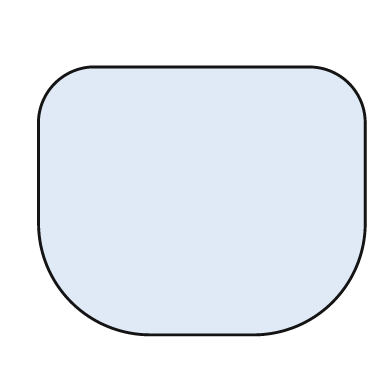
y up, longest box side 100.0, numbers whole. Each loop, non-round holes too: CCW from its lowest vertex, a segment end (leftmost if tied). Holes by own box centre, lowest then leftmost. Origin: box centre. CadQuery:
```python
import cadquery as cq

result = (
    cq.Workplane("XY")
    .moveTo(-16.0, -41.0)
    .lineTo(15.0, -41.0)
    .threePointArc((40.0, -31.0), (50.0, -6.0))
    .lineTo(50.0, 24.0)
    .threePointArc((45.0, 36.0), (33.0, 41.0))
    .lineTo(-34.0, 41.0)
    .threePointArc((-45.0, 36.0), (-50.0, 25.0))
    .lineTo(-50.0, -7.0)
    .threePointArc((-40.0, -31.0), (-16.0, -41.0))
    .close()
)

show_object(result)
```